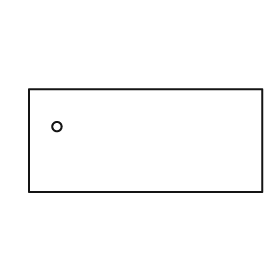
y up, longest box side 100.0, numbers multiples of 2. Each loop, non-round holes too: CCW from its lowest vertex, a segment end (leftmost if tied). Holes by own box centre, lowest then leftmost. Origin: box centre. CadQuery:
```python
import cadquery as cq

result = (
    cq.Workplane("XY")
    .moveTo(-50.0, -22.0)
    .lineTo(50.0, -22.0)
    .lineTo(50.0, 22.0)
    .lineTo(-50.0, 22.0)
    .close()
    .moveTo(-38.0, 6.0)
    .circle(2.0)
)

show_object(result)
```